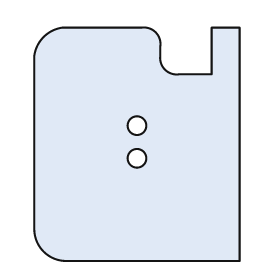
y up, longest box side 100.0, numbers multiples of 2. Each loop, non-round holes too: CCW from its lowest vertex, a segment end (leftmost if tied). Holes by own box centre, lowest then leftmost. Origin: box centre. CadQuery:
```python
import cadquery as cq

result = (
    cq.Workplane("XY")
    .moveTo(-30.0, -50.0)
    .lineTo(44.0, -50.0)
    .lineTo(44.0, 50.0)
    .lineTo(32.0, 50.0)
    .lineTo(32.0, 30.0)
    .lineTo(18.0, 30.0)
    .threePointArc((12.0, 32.0), (10.0, 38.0))
    .lineTo(10.0, 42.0)
    .threePointArc((8.0, 48.0), (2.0, 50.0))
    .lineTo(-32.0, 50.0)
    .threePointArc((-40.0, 46.0), (-44.0, 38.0))
    .lineTo(-44.0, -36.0)
    .threePointArc((-40.0, -46.0), (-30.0, -50.0))
    .close()
    .moveTo(0.0, -6.0)
    .circle(4.0)
    .moveTo(0.0, 8.0)
    .circle(4.0)
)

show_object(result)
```